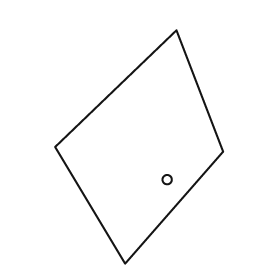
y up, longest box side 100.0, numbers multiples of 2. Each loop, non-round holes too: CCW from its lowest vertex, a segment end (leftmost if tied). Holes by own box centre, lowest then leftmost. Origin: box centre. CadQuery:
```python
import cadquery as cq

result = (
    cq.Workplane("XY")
    .moveTo(-6.0, -50.0)
    .lineTo(36.0, -2.0)
    .lineTo(16.0, 50.0)
    .lineTo(-36.0, 0.0)
    .close()
    .moveTo(12.0, -14.0)
    .circle(2.0)
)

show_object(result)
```